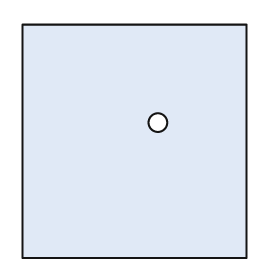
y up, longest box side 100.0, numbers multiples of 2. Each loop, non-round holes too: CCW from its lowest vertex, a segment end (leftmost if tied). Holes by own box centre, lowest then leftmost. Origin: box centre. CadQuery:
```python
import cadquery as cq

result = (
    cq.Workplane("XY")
    .moveTo(-48.0, -50.0)
    .lineTo(48.0, -50.0)
    .lineTo(48.0, 50.0)
    .lineTo(-48.0, 50.0)
    .close()
    .moveTo(10.0, 8.0)
    .circle(4.0)
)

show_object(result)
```